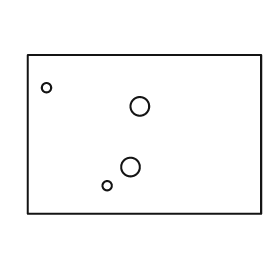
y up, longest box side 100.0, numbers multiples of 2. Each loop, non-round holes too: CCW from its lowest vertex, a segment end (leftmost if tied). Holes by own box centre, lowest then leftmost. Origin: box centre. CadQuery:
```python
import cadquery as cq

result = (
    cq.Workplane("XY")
    .moveTo(-50.0, -34.0)
    .lineTo(50.0, -34.0)
    .lineTo(50.0, 34.0)
    .lineTo(-50.0, 34.0)
    .close()
    .moveTo(-16.0, -22.0)
    .circle(2.0)
    .moveTo(-6.0, -14.0)
    .circle(4.0)
    .moveTo(-2.0, 12.0)
    .circle(4.0)
    .moveTo(-42.0, 20.0)
    .circle(2.0)
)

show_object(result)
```